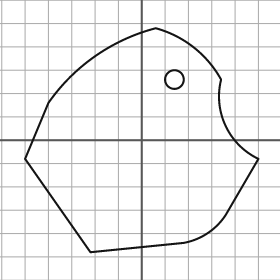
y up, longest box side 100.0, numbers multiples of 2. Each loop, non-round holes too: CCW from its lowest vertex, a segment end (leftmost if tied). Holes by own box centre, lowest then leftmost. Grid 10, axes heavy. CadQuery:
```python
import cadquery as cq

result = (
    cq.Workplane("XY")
    .moveTo(-22.0, -48.0)
    .lineTo(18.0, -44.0)
    .threePointArc((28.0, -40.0), (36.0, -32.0))
    .lineTo(50.0, -8.0)
    .threePointArc((36.0, 6.0), (34.0, 26.0))
    .threePointArc((22.0, 40.0), (6.0, 48.0))
    .threePointArc((-20.0, 36.0), (-40.0, 16.0))
    .lineTo(-50.0, -8.0)
    .close()
    .moveTo(14.0, 26.0)
    .circle(4.0)
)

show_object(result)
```